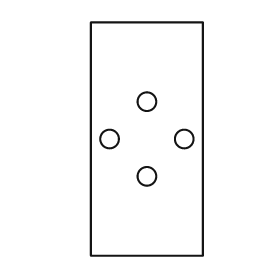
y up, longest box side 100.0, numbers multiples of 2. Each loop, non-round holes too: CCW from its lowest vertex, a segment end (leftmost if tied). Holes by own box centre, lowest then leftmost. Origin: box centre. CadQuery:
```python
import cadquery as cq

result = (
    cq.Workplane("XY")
    .moveTo(-24.0, -50.0)
    .lineTo(24.0, -50.0)
    .lineTo(24.0, 50.0)
    .lineTo(-24.0, 50.0)
    .close()
    .moveTo(0.0, -16.0)
    .circle(4.0)
    .moveTo(-16.0, 0.0)
    .circle(4.0)
    .moveTo(16.0, 0.0)
    .circle(4.0)
    .moveTo(0.0, 16.0)
    .circle(4.0)
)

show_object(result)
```